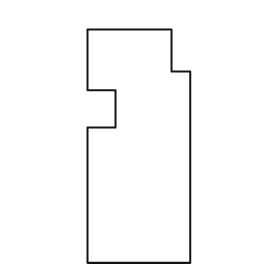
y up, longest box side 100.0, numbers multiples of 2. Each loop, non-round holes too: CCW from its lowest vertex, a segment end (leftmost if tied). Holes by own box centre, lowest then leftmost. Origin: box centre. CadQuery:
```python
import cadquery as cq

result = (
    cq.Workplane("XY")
    .moveTo(-22.0, -50.0)
    .lineTo(22.0, -50.0)
    .lineTo(22.0, 32.0)
    .lineTo(14.0, 32.0)
    .lineTo(14.0, 50.0)
    .lineTo(-22.0, 50.0)
    .lineTo(-22.0, 24.0)
    .lineTo(-10.0, 24.0)
    .lineTo(-10.0, 8.0)
    .lineTo(-22.0, 8.0)
    .close()
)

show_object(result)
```